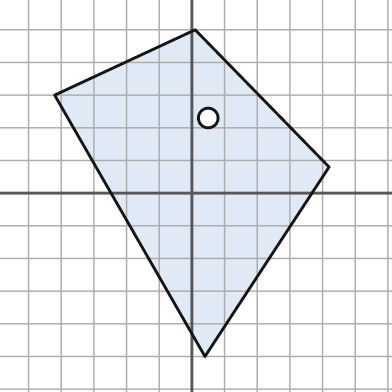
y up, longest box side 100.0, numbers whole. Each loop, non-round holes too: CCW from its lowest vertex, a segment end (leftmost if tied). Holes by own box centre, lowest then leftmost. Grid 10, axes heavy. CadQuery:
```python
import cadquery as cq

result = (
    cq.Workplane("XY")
    .moveTo(4.0, -50.0)
    .lineTo(42.0, 8.0)
    .lineTo(1.0, 50.0)
    .lineTo(-42.0, 30.0)
    .close()
    .moveTo(5.0, 23.0)
    .circle(3.0)
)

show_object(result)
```